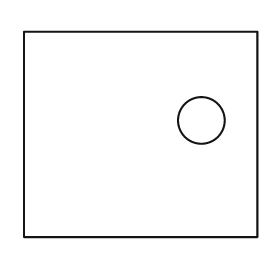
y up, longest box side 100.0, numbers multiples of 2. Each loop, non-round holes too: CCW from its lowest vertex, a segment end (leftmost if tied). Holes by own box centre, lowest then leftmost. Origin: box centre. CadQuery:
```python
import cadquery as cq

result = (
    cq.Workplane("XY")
    .moveTo(-50.0, -44.0)
    .lineTo(50.0, -44.0)
    .lineTo(50.0, 44.0)
    .lineTo(-50.0, 44.0)
    .close()
    .moveTo(26.0, 6.0)
    .circle(10.0)
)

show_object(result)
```